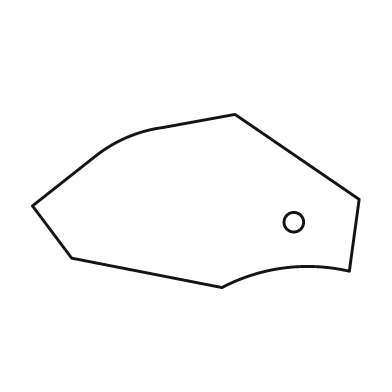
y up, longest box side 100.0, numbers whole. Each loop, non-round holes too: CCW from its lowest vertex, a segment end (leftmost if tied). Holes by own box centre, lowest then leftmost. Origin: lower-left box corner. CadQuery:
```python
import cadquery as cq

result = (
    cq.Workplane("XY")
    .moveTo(58.0, 0.0)
    .threePointArc((77.0, 6.0), (97.0, 5.0))
    .lineTo(100.0, 27.0)
    .lineTo(62.0, 53.0)
    .lineTo(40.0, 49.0)
    .threePointArc((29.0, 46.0), (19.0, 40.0))
    .lineTo(0.0, 25.0)
    .lineTo(12.0, 9.0)
    .close()
    .moveTo(80.0, 20.0)
    .circle(3.0)
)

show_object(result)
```